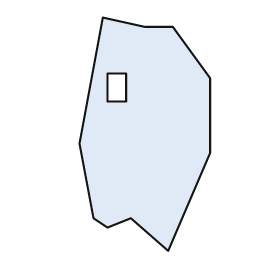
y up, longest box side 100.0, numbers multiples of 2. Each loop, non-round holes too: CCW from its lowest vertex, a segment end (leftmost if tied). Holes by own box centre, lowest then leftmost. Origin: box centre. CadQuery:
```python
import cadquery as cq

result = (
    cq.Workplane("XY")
    .moveTo(10.0, -50.0)
    .lineTo(28.0, -8.0)
    .lineTo(28.0, 24.0)
    .lineTo(12.0, 46.0)
    .lineTo(0.0, 46.0)
    .lineTo(-18.0, 50.0)
    .lineTo(-28.0, -4.0)
    .lineTo(-22.0, -36.0)
    .lineTo(-16.0, -40.0)
    .lineTo(-6.0, -36.0)
    .close()
    .moveTo(-16.0, 14.0)
    .lineTo(-8.0, 14.0)
    .lineTo(-8.0, 26.0)
    .lineTo(-16.0, 26.0)
    .close()
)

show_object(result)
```